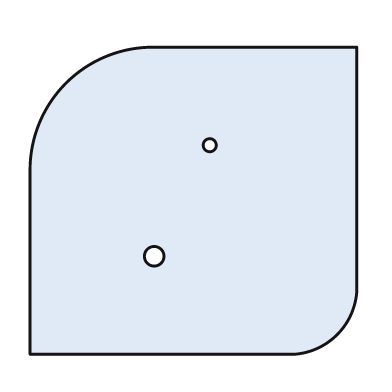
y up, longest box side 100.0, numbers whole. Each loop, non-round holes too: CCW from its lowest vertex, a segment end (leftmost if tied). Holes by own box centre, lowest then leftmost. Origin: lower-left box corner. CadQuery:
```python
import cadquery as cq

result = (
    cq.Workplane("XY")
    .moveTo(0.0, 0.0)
    .lineTo(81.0, 0.0)
    .threePointArc((94.0, 6.0), (100.0, 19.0))
    .lineTo(100.0, 94.0)
    .lineTo(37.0, 94.0)
    .threePointArc((11.0, 83.0), (0.0, 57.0))
    .close()
    .moveTo(38.0, 30.0)
    .circle(3.0)
    .moveTo(55.0, 64.0)
    .circle(2.0)
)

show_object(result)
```